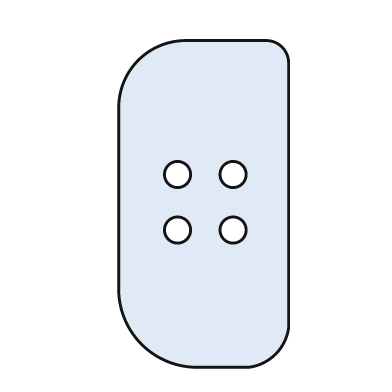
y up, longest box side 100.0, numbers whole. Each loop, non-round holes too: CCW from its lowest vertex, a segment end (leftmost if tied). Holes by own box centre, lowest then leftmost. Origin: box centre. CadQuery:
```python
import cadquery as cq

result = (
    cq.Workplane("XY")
    .moveTo(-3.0, -50.0)
    .lineTo(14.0, -50.0)
    .threePointArc((22.0, -46.0), (26.0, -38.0))
    .lineTo(26.0, 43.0)
    .threePointArc((24.0, 48.0), (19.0, 50.0))
    .lineTo(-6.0, 50.0)
    .threePointArc((-20.0, 44.0), (-26.0, 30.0))
    .lineTo(-26.0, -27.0)
    .threePointArc((-19.0, -43.0), (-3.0, -50.0))
    .close()
    .moveTo(-8.0, -8.0)
    .circle(4.0)
    .moveTo(9.0, -8.0)
    .circle(4.0)
    .moveTo(-8.0, 9.0)
    .circle(4.0)
    .moveTo(9.0, 9.0)
    .circle(4.0)
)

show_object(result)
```